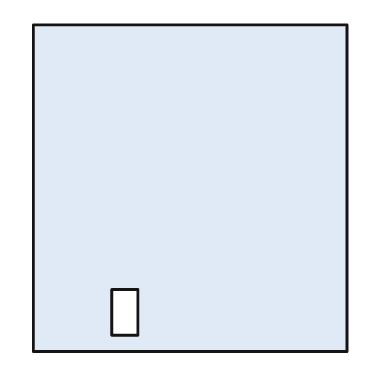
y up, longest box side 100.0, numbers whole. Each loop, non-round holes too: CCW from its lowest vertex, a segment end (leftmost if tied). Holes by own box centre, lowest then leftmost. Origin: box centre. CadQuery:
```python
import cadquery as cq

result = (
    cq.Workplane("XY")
    .moveTo(-48.0, -50.0)
    .lineTo(48.0, -50.0)
    .lineTo(48.0, 50.0)
    .lineTo(-48.0, 50.0)
    .close()
    .moveTo(-24.0, -45.0)
    .lineTo(-16.0, -45.0)
    .lineTo(-16.0, -31.0)
    .lineTo(-24.0, -31.0)
    .close()
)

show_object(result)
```